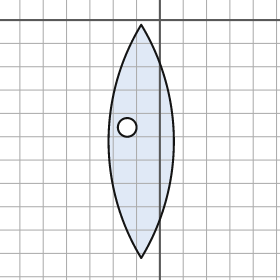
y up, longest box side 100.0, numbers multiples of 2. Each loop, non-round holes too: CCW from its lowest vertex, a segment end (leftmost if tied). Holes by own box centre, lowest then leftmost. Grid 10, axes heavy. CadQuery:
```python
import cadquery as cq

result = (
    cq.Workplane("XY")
    .moveTo(-8.0, -102.0)
    .threePointArc((6.0, -52.0), (-8.0, -2.0))
    .threePointArc((-22.0, -52.0), (-8.0, -102.0))
    .close()
    .moveTo(-14.0, -46.0)
    .circle(4.0)
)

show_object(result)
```